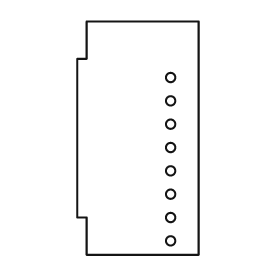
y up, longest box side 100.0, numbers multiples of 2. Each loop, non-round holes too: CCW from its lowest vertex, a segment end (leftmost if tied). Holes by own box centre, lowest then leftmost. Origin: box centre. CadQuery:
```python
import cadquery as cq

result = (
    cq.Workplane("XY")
    .moveTo(-22.0, -50.0)
    .lineTo(26.0, -50.0)
    .lineTo(26.0, 50.0)
    .lineTo(-22.0, 50.0)
    .lineTo(-22.0, 34.0)
    .lineTo(-26.0, 34.0)
    .lineTo(-26.0, -34.0)
    .lineTo(-22.0, -34.0)
    .close()
    .moveTo(14.0, -44.0)
    .circle(2.0)
    .moveTo(14.0, -34.0)
    .circle(2.0)
    .moveTo(14.0, -24.0)
    .circle(2.0)
    .moveTo(14.0, -14.0)
    .circle(2.0)
    .moveTo(14.0, -4.0)
    .circle(2.0)
    .moveTo(14.0, 6.0)
    .circle(2.0)
    .moveTo(14.0, 16.0)
    .circle(2.0)
    .moveTo(14.0, 26.0)
    .circle(2.0)
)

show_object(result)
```